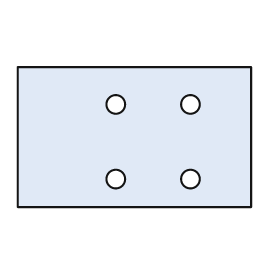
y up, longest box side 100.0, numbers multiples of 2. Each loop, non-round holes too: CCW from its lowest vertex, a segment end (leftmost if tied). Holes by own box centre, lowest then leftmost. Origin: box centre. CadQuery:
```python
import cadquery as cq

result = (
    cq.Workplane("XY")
    .moveTo(-50.0, -30.0)
    .lineTo(50.0, -30.0)
    .lineTo(50.0, 30.0)
    .lineTo(-50.0, 30.0)
    .close()
    .moveTo(-8.0, -18.0)
    .circle(4.0)
    .moveTo(24.0, -18.0)
    .circle(4.0)
    .moveTo(-8.0, 14.0)
    .circle(4.0)
    .moveTo(24.0, 14.0)
    .circle(4.0)
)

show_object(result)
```